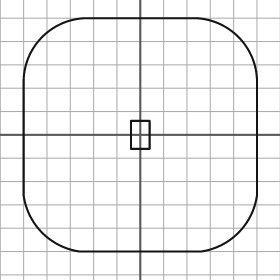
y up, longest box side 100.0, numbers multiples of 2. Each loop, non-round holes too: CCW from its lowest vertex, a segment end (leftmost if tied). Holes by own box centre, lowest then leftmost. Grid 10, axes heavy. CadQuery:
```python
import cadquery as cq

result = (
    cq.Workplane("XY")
    .moveTo(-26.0, -50.0)
    .lineTo(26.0, -50.0)
    .threePointArc((42.0, -42.0), (50.0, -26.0))
    .lineTo(50.0, 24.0)
    .threePointArc((42.0, 42.0), (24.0, 50.0))
    .lineTo(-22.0, 50.0)
    .threePointArc((-42.0, 42.0), (-50.0, 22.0))
    .lineTo(-50.0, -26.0)
    .threePointArc((-42.0, -42.0), (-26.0, -50.0))
    .close()
    .moveTo(-4.0, -6.0)
    .lineTo(4.0, -6.0)
    .lineTo(4.0, 6.0)
    .lineTo(-4.0, 6.0)
    .close()
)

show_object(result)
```